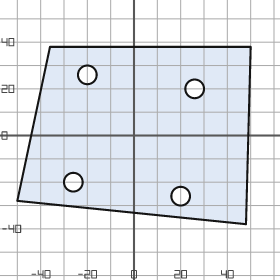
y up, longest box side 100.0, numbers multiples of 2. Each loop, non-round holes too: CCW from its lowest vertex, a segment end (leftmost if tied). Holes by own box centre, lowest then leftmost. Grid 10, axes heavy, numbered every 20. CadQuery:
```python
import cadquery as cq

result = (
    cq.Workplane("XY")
    .moveTo(48.0, -38.0)
    .lineTo(50.0, 38.0)
    .lineTo(-36.0, 38.0)
    .lineTo(-50.0, -28.0)
    .close()
    .moveTo(20.0, -26.0)
    .circle(4.0)
    .moveTo(-26.0, -20.0)
    .circle(4.0)
    .moveTo(26.0, 20.0)
    .circle(4.0)
    .moveTo(-20.0, 26.0)
    .circle(4.0)
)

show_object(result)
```